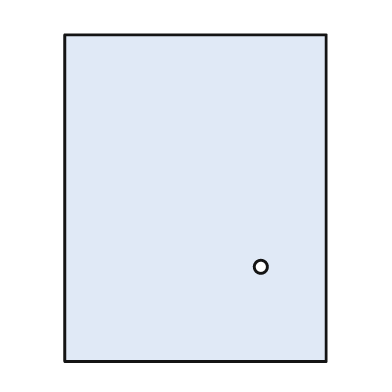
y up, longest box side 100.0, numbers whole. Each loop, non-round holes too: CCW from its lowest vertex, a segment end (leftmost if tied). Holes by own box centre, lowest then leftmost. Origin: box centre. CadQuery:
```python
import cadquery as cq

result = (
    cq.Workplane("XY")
    .moveTo(-40.0, -50.0)
    .lineTo(40.0, -50.0)
    .lineTo(40.0, 50.0)
    .lineTo(-40.0, 50.0)
    .close()
    .moveTo(20.0, -21.0)
    .circle(2.0)
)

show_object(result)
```